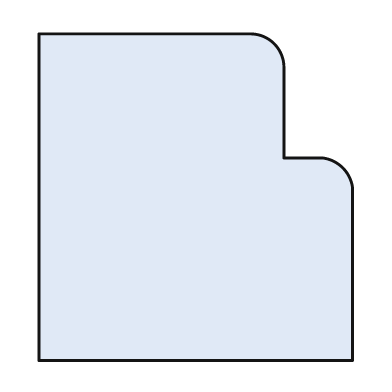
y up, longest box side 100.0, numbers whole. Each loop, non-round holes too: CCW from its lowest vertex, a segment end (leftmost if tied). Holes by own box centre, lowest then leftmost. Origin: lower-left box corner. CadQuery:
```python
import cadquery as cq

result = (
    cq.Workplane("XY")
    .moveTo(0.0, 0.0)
    .lineTo(96.0, 0.0)
    .lineTo(96.0, 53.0)
    .threePointArc((93.0, 59.0), (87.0, 62.0))
    .lineTo(75.0, 62.0)
    .lineTo(75.0, 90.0)
    .threePointArc((72.0, 97.0), (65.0, 100.0))
    .lineTo(0.0, 100.0)
    .close()
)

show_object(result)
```